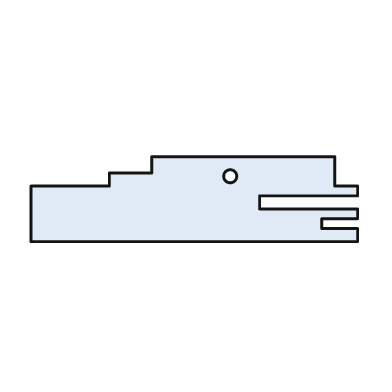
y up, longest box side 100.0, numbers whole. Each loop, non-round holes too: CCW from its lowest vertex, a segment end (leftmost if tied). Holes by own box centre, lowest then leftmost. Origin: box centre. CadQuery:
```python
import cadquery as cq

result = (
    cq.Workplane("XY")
    .moveTo(-50.0, -13.0)
    .lineTo(50.0, -13.0)
    .lineTo(50.0, -9.0)
    .lineTo(39.0, -9.0)
    .lineTo(39.0, -6.0)
    .lineTo(50.0, -6.0)
    .lineTo(50.0, -3.0)
    .lineTo(20.0, -3.0)
    .lineTo(20.0, 1.0)
    .lineTo(50.0, 1.0)
    .lineTo(50.0, 4.0)
    .lineTo(43.0, 4.0)
    .lineTo(43.0, 13.0)
    .lineTo(-13.0, 13.0)
    .lineTo(-13.0, 8.0)
    .lineTo(-26.0, 8.0)
    .lineTo(-26.0, 4.0)
    .lineTo(-50.0, 4.0)
    .close()
    .moveTo(11.0, 7.0)
    .circle(2.0)
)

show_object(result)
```